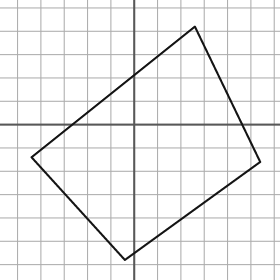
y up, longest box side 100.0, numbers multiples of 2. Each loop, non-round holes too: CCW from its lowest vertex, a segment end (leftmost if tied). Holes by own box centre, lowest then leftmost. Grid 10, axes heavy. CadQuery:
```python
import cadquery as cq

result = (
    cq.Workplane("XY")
    .moveTo(-4.0, -58.0)
    .lineTo(54.0, -16.0)
    .lineTo(26.0, 42.0)
    .lineTo(-44.0, -14.0)
    .close()
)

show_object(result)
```